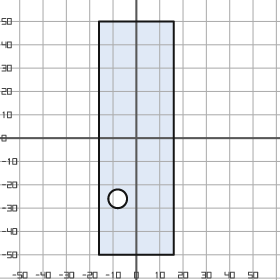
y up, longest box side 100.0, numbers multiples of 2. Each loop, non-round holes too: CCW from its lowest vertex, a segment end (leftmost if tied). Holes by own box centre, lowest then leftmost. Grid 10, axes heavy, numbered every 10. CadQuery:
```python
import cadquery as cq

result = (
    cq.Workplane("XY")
    .moveTo(-16.0, -50.0)
    .lineTo(16.0, -50.0)
    .lineTo(16.0, 50.0)
    .lineTo(-16.0, 50.0)
    .close()
    .moveTo(-8.0, -26.0)
    .circle(4.0)
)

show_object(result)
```